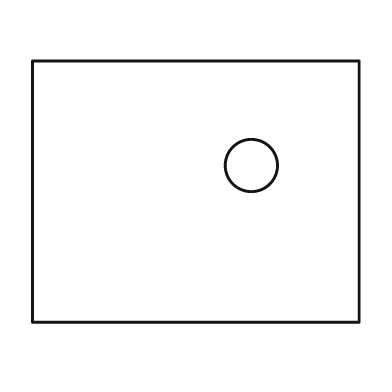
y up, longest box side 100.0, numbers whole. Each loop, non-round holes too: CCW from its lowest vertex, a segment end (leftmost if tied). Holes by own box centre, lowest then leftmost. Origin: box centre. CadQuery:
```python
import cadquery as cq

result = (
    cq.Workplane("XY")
    .moveTo(-50.0, -40.0)
    .lineTo(50.0, -40.0)
    .lineTo(50.0, 40.0)
    .lineTo(-50.0, 40.0)
    .close()
    .moveTo(17.0, 8.0)
    .circle(8.0)
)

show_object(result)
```